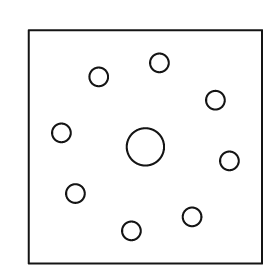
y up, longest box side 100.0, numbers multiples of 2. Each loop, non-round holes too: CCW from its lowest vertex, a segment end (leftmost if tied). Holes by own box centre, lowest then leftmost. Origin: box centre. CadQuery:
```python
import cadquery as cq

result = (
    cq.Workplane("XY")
    .moveTo(-50.0, -50.0)
    .lineTo(50.0, -50.0)
    .lineTo(50.0, 50.0)
    .lineTo(-50.0, 50.0)
    .close()
    .moveTo(-6.0, -36.0)
    .circle(4.0)
    .moveTo(20.0, -30.0)
    .circle(4.0)
    .moveTo(-30.0, -20.0)
    .circle(4.0)
    .moveTo(36.0, -6.0)
    .circle(4.0)
    .moveTo(0.0, 0.0)
    .circle(8.0)
    .moveTo(-36.0, 6.0)
    .circle(4.0)
    .moveTo(30.0, 20.0)
    .circle(4.0)
    .moveTo(-20.0, 30.0)
    .circle(4.0)
    .moveTo(6.0, 36.0)
    .circle(4.0)
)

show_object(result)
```